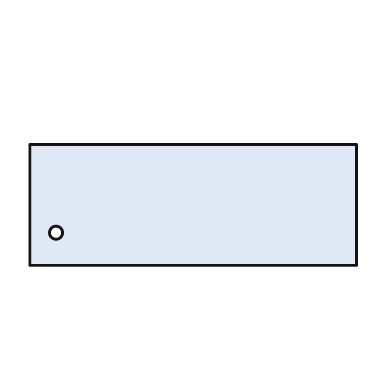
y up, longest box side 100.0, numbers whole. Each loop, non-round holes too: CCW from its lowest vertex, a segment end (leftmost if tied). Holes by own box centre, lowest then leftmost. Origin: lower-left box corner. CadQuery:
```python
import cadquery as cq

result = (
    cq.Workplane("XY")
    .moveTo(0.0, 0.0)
    .lineTo(100.0, 0.0)
    .lineTo(100.0, 37.0)
    .lineTo(0.0, 37.0)
    .close()
    .moveTo(8.0, 10.0)
    .circle(2.0)
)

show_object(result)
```